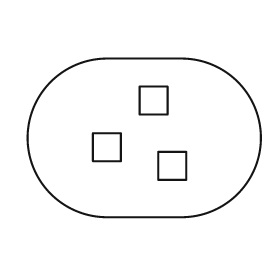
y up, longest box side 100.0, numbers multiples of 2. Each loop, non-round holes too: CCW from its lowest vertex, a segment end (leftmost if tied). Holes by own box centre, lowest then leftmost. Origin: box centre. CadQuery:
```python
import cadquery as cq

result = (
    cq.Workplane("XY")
    .moveTo(-16.0, -34.0)
    .lineTo(16.0, -34.0)
    .threePointArc((50.0, 0.0), (16.0, 34.0))
    .lineTo(-16.0, 34.0)
    .threePointArc((-50.0, 0.0), (-16.0, -34.0))
    .close()
    .moveTo(6.0, -18.0)
    .lineTo(18.0, -18.0)
    .lineTo(18.0, -6.0)
    .lineTo(6.0, -6.0)
    .close()
    .moveTo(-22.0, -10.0)
    .lineTo(-10.0, -10.0)
    .lineTo(-10.0, 2.0)
    .lineTo(-22.0, 2.0)
    .close()
    .moveTo(-2.0, 10.0)
    .lineTo(10.0, 10.0)
    .lineTo(10.0, 22.0)
    .lineTo(-2.0, 22.0)
    .close()
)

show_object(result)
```